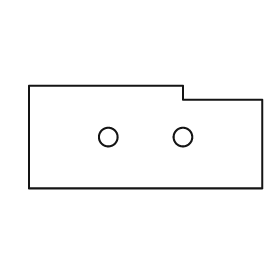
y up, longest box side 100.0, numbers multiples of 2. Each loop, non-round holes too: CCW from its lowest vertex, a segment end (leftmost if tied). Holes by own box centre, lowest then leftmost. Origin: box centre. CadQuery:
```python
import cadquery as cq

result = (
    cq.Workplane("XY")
    .moveTo(-50.0, -22.0)
    .lineTo(50.0, -22.0)
    .lineTo(50.0, 16.0)
    .lineTo(16.0, 16.0)
    .lineTo(16.0, 22.0)
    .lineTo(-50.0, 22.0)
    .close()
    .moveTo(-16.0, 0.0)
    .circle(4.0)
    .moveTo(16.0, 0.0)
    .circle(4.0)
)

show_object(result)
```